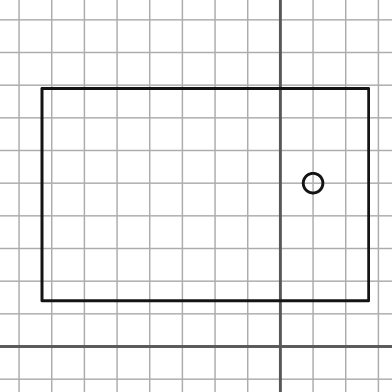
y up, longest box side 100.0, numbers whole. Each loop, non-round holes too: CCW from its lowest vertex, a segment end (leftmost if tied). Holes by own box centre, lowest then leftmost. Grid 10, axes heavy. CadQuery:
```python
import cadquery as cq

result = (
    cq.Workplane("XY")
    .moveTo(-73.0, 14.0)
    .lineTo(27.0, 14.0)
    .lineTo(27.0, 79.0)
    .lineTo(-73.0, 79.0)
    .close()
    .moveTo(10.0, 50.0)
    .circle(3.0)
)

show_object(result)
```